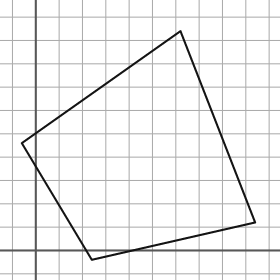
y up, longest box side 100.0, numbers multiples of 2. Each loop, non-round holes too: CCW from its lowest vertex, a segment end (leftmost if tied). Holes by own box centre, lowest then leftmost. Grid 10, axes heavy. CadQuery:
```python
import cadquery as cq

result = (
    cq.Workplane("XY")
    .moveTo(24.0, -4.0)
    .lineTo(94.0, 12.0)
    .lineTo(62.0, 94.0)
    .lineTo(-6.0, 46.0)
    .close()
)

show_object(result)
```